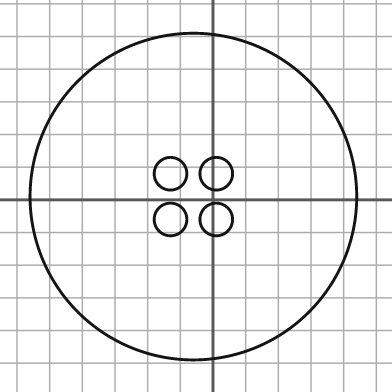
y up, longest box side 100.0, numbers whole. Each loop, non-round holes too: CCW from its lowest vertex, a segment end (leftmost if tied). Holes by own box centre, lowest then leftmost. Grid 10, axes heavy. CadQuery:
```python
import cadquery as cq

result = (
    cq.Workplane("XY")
    .moveTo(-6.0, 1.0)
    .circle(50.0)
    .moveTo(-13.0, -6.0)
    .circle(5.0)
    .moveTo(1.0, -6.0)
    .circle(5.0)
    .moveTo(-13.0, 8.0)
    .circle(5.0)
    .moveTo(1.0, 8.0)
    .circle(5.0)
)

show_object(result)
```